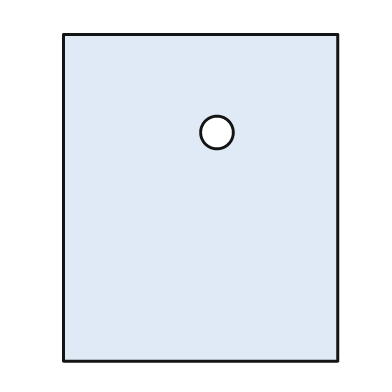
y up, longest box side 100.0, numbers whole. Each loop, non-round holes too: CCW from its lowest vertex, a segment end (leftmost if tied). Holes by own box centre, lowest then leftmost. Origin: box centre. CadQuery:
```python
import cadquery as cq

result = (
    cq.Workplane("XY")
    .moveTo(-42.0, -50.0)
    .lineTo(42.0, -50.0)
    .lineTo(42.0, 50.0)
    .lineTo(-42.0, 50.0)
    .close()
    .moveTo(5.0, 20.0)
    .circle(5.0)
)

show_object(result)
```